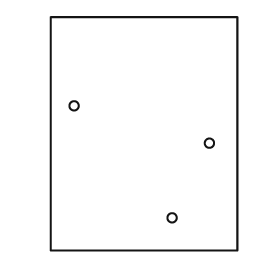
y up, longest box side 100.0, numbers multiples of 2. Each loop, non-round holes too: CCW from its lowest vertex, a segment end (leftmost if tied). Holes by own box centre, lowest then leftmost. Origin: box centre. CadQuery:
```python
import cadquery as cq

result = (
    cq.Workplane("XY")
    .moveTo(-40.0, -50.0)
    .lineTo(40.0, -50.0)
    .lineTo(40.0, 50.0)
    .lineTo(-40.0, 50.0)
    .close()
    .moveTo(12.0, -36.0)
    .circle(2.0)
    .moveTo(28.0, -4.0)
    .circle(2.0)
    .moveTo(-30.0, 12.0)
    .circle(2.0)
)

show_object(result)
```